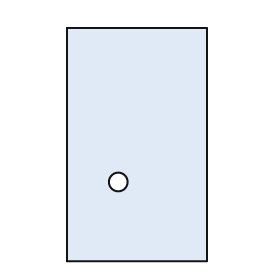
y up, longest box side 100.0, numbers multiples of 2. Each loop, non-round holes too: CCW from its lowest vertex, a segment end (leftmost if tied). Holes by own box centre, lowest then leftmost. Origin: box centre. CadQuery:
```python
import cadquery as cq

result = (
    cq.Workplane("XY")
    .moveTo(-30.0, -50.0)
    .lineTo(30.0, -50.0)
    .lineTo(30.0, 50.0)
    .lineTo(-30.0, 50.0)
    .close()
    .moveTo(-8.0, -16.0)
    .circle(4.0)
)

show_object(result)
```